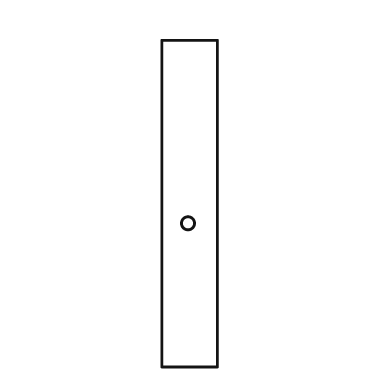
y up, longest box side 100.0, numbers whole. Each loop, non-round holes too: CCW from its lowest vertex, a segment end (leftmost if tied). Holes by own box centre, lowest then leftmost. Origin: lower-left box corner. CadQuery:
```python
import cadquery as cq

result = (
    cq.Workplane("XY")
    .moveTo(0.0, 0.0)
    .lineTo(17.0, 0.0)
    .lineTo(17.0, 100.0)
    .lineTo(0.0, 100.0)
    .close()
    .moveTo(8.0, 44.0)
    .circle(2.0)
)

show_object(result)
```